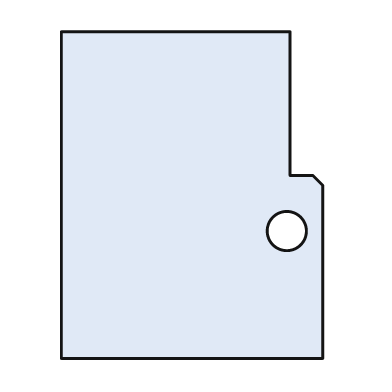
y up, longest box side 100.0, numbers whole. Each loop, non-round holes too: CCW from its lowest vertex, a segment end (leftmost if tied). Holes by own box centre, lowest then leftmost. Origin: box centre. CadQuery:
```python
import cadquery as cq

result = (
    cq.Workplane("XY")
    .moveTo(-40.0, -50.0)
    .lineTo(40.0, -50.0)
    .lineTo(40.0, 3.0)
    .lineTo(37.0, 6.0)
    .lineTo(30.0, 6.0)
    .lineTo(30.0, 50.0)
    .lineTo(-40.0, 50.0)
    .close()
    .moveTo(29.0, -11.0)
    .circle(6.0)
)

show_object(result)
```